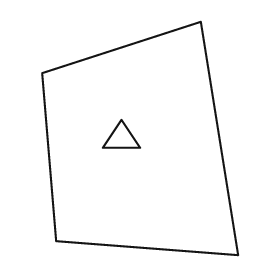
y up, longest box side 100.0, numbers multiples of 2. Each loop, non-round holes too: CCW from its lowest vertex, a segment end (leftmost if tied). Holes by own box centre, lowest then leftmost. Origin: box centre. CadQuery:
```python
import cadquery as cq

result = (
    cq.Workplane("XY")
    .moveTo(42.0, -50.0)
    .lineTo(26.0, 50.0)
    .lineTo(-42.0, 28.0)
    .lineTo(-36.0, -44.0)
    .close()
    .moveTo(-16.0, -4.0)
    .lineTo(0.0, -4.0)
    .lineTo(-8.0, 8.0)
    .close()
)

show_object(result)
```